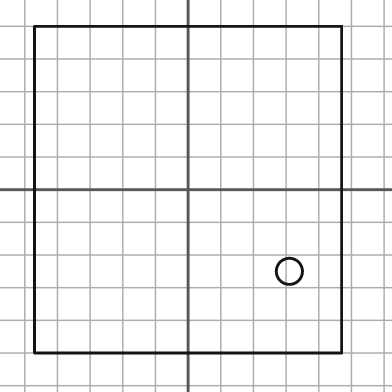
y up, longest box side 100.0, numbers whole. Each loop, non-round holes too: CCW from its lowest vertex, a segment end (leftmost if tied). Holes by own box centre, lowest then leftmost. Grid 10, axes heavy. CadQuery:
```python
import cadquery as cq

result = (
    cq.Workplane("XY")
    .moveTo(-47.0, -50.0)
    .lineTo(47.0, -50.0)
    .lineTo(47.0, 50.0)
    .lineTo(-47.0, 50.0)
    .close()
    .moveTo(31.0, -25.0)
    .circle(4.0)
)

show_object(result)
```